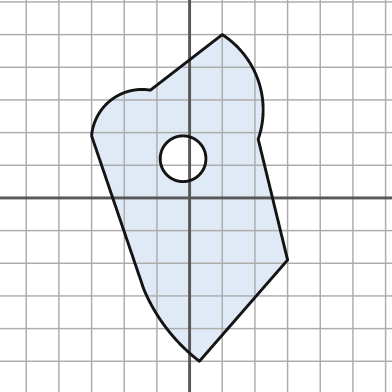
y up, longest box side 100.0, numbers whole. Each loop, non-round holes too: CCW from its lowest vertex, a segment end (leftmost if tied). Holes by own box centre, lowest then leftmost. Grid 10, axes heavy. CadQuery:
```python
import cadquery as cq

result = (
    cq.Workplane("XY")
    .moveTo(3.0, -50.0)
    .lineTo(30.0, -19.0)
    .lineTo(21.0, 18.0)
    .threePointArc((21.0, 36.0), (10.0, 50.0))
    .lineTo(-12.0, 33.0)
    .threePointArc((-24.0, 30.0), (-30.0, 19.0))
    .lineTo(-14.0, -28.0)
    .threePointArc((-7.0, -40.0), (3.0, -50.0))
    .close()
    .moveTo(-2.0, 12.0)
    .circle(7.0)
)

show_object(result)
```